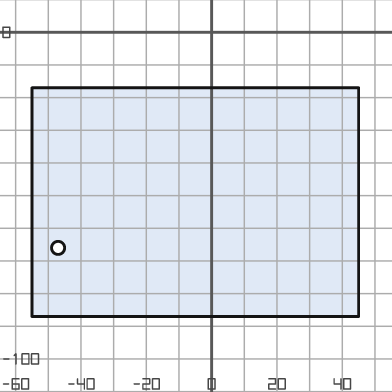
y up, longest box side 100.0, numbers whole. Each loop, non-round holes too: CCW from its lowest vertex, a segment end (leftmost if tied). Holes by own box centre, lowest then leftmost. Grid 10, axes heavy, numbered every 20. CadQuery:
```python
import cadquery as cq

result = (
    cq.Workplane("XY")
    .moveTo(-55.0, -87.0)
    .lineTo(45.0, -87.0)
    .lineTo(45.0, -17.0)
    .lineTo(-55.0, -17.0)
    .close()
    .moveTo(-47.0, -66.0)
    .circle(2.0)
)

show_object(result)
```